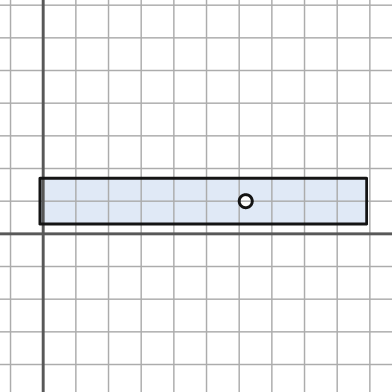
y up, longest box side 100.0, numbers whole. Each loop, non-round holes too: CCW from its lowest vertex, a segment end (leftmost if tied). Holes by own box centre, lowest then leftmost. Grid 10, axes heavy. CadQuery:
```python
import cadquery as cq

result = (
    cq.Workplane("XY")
    .moveTo(-1.0, 3.0)
    .lineTo(99.0, 3.0)
    .lineTo(99.0, 17.0)
    .lineTo(-1.0, 17.0)
    .close()
    .moveTo(62.0, 10.0)
    .circle(2.0)
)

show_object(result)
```